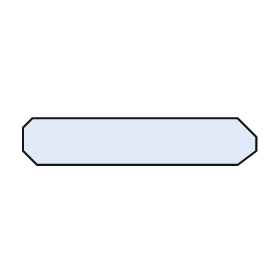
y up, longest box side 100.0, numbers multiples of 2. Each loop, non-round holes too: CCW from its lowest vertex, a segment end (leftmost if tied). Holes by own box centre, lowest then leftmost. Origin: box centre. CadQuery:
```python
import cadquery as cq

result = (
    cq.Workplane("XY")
    .moveTo(-44.0, -10.0)
    .lineTo(42.0, -10.0)
    .lineTo(50.0, -4.0)
    .lineTo(50.0, 2.0)
    .lineTo(42.0, 10.0)
    .lineTo(-46.0, 10.0)
    .lineTo(-50.0, 6.0)
    .lineTo(-50.0, -4.0)
    .close()
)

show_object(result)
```